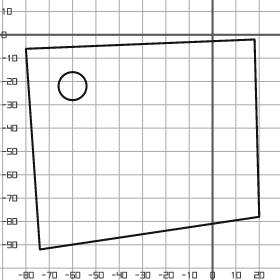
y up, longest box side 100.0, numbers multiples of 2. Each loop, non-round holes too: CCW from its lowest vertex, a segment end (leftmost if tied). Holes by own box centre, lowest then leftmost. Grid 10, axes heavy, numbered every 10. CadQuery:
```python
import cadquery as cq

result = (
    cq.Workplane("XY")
    .moveTo(-74.0, -92.0)
    .lineTo(20.0, -78.0)
    .lineTo(18.0, -2.0)
    .lineTo(-80.0, -6.0)
    .close()
    .moveTo(-60.0, -22.0)
    .circle(6.0)
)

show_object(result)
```